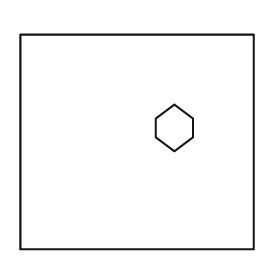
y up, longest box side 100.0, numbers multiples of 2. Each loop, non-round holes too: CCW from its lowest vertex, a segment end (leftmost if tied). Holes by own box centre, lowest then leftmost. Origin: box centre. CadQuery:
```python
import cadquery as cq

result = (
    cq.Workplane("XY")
    .moveTo(-50.0, -46.0)
    .lineTo(50.0, -46.0)
    .lineTo(50.0, 46.0)
    .lineTo(-50.0, 46.0)
    .close()
    .moveTo(16.0, -4.0)
    .lineTo(24.0, 2.0)
    .lineTo(24.0, 10.0)
    .lineTo(16.0, 16.0)
    .lineTo(8.0, 10.0)
    .lineTo(8.0, 2.0)
    .close()
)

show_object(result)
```